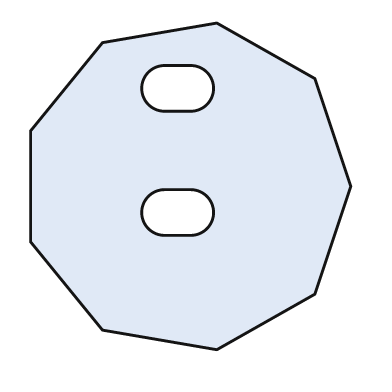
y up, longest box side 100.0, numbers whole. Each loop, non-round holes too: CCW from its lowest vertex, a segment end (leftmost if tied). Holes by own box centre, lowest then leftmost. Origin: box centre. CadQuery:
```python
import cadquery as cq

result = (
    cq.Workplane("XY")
    .moveTo(8.0, -50.0)
    .lineTo(38.0, -33.0)
    .lineTo(49.0, 0.0)
    .lineTo(38.0, 33.0)
    .lineTo(8.0, 50.0)
    .lineTo(-27.0, 44.0)
    .lineTo(-49.0, 17.0)
    .lineTo(-49.0, -17.0)
    .lineTo(-27.0, -44.0)
    .close()
    .moveTo(-8.0, -15.0)
    .lineTo(0.0, -15.0)
    .threePointArc((7.0, -8.0), (0.0, -1.0))
    .lineTo(-8.0, -1.0)
    .threePointArc((-15.0, -8.0), (-8.0, -15.0))
    .close()
    .moveTo(-8.0, 23.0)
    .lineTo(0.0, 23.0)
    .threePointArc((7.0, 30.0), (0.0, 37.0))
    .lineTo(-8.0, 37.0)
    .threePointArc((-15.0, 30.0), (-8.0, 23.0))
    .close()
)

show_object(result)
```